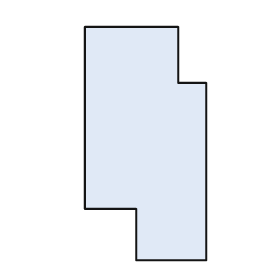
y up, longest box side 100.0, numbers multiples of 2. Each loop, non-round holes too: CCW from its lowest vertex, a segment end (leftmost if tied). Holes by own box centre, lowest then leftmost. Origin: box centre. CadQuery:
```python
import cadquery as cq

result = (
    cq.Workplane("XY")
    .moveTo(-4.0, -50.0)
    .lineTo(26.0, -50.0)
    .lineTo(26.0, 26.0)
    .lineTo(14.0, 26.0)
    .lineTo(14.0, 50.0)
    .lineTo(-26.0, 50.0)
    .lineTo(-26.0, -28.0)
    .lineTo(-4.0, -28.0)
    .close()
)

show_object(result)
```